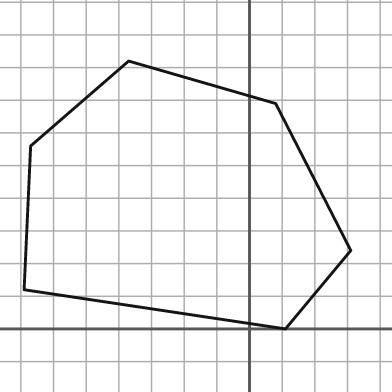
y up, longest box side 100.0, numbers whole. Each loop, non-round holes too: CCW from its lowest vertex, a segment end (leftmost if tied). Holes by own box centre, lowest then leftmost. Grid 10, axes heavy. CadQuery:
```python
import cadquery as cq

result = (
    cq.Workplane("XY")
    .moveTo(11.0, 0.0)
    .lineTo(31.0, 24.0)
    .lineTo(8.0, 69.0)
    .lineTo(-37.0, 82.0)
    .lineTo(-67.0, 56.0)
    .lineTo(-69.0, 12.0)
    .close()
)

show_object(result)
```